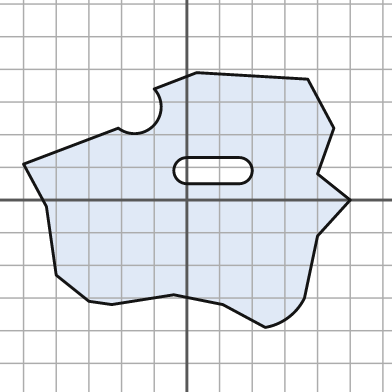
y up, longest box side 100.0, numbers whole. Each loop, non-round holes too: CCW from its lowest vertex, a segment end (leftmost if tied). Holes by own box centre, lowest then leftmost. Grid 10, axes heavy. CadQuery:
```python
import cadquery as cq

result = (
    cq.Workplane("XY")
    .moveTo(24.0, -39.0)
    .threePointArc((31.0, -36.0), (36.0, -30.0))
    .lineTo(40.0, -11.0)
    .lineTo(50.0, 0.0)
    .lineTo(40.0, 8.0)
    .lineTo(45.0, 22.0)
    .lineTo(37.0, 37.0)
    .lineTo(3.0, 39.0)
    .lineTo(-10.0, 34.0)
    .threePointArc((-10.0, 23.0), (-21.0, 22.0))
    .lineTo(-50.0, 11.0)
    .lineTo(-43.0, -2.0)
    .lineTo(-40.0, -23.0)
    .lineTo(-30.0, -31.0)
    .lineTo(-23.0, -32.0)
    .lineTo(-4.0, -29.0)
    .lineTo(11.0, -32.0)
    .close()
    .moveTo(0.0, 5.0)
    .lineTo(16.0, 5.0)
    .threePointArc((20.0, 9.0), (16.0, 13.0))
    .lineTo(0.0, 13.0)
    .threePointArc((-4.0, 9.0), (0.0, 5.0))
    .close()
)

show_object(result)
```